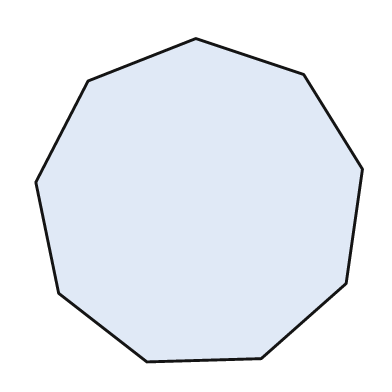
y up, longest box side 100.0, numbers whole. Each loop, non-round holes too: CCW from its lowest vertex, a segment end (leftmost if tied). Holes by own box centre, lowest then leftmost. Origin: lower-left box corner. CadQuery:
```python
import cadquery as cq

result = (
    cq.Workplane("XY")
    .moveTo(34.0, 0.0)
    .lineTo(69.0, 1.0)
    .lineTo(95.0, 24.0)
    .lineTo(100.0, 59.0)
    .lineTo(82.0, 88.0)
    .lineTo(49.0, 99.0)
    .lineTo(16.0, 86.0)
    .lineTo(0.0, 55.0)
    .lineTo(7.0, 21.0)
    .close()
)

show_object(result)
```